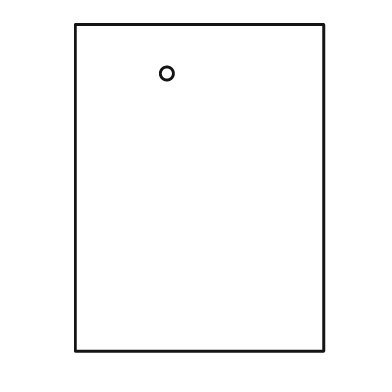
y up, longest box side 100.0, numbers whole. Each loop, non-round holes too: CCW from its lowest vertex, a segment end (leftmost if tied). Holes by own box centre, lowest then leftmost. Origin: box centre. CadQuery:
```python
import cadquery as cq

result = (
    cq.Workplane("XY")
    .moveTo(-38.0, -50.0)
    .lineTo(38.0, -50.0)
    .lineTo(38.0, 50.0)
    .lineTo(-38.0, 50.0)
    .close()
    .moveTo(-10.0, 35.0)
    .circle(2.0)
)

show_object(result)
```